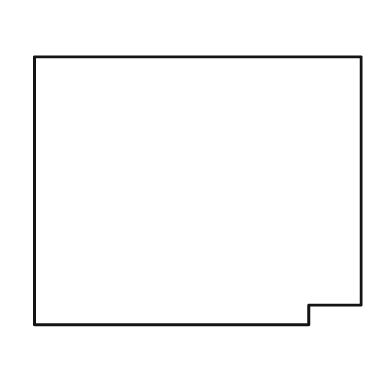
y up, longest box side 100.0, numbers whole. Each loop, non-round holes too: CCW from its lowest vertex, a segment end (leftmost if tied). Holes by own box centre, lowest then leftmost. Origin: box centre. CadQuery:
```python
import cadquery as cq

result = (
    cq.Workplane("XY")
    .moveTo(-50.0, -41.0)
    .lineTo(34.0, -41.0)
    .lineTo(34.0, -35.0)
    .lineTo(50.0, -35.0)
    .lineTo(50.0, 41.0)
    .lineTo(-50.0, 41.0)
    .close()
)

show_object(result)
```